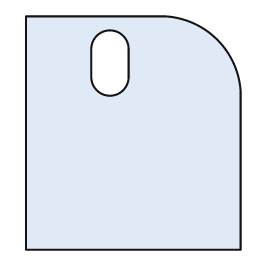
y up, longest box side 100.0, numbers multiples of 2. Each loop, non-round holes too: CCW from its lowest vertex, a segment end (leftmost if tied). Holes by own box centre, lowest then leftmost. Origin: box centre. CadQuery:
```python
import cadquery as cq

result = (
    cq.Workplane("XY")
    .moveTo(-46.0, -50.0)
    .lineTo(46.0, -50.0)
    .lineTo(46.0, 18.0)
    .threePointArc((36.0, 40.0), (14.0, 50.0))
    .lineTo(-46.0, 50.0)
    .close()
    .moveTo(-18.0, 24.0)
    .threePointArc((-10.0, 16.0), (-2.0, 24.0))
    .lineTo(-2.0, 36.0)
    .threePointArc((-10.0, 44.0), (-18.0, 36.0))
    .close()
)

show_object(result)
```